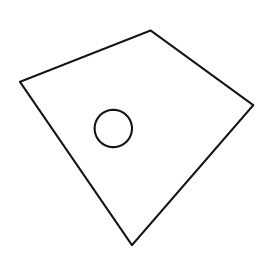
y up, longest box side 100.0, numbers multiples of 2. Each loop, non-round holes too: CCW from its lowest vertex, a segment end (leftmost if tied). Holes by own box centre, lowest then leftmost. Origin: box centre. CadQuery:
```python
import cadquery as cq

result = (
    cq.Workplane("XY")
    .moveTo(-2.0, -46.0)
    .lineTo(50.0, 14.0)
    .lineTo(6.0, 46.0)
    .lineTo(-50.0, 24.0)
    .close()
    .moveTo(-10.0, 4.0)
    .circle(8.0)
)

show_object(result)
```